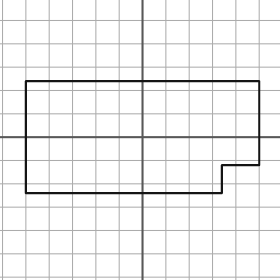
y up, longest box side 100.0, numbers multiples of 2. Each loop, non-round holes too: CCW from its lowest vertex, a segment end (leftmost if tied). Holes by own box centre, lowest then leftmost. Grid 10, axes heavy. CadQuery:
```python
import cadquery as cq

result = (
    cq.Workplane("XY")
    .moveTo(-50.0, -24.0)
    .lineTo(34.0, -24.0)
    .lineTo(34.0, -12.0)
    .lineTo(50.0, -12.0)
    .lineTo(50.0, 24.0)
    .lineTo(-50.0, 24.0)
    .close()
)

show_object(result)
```